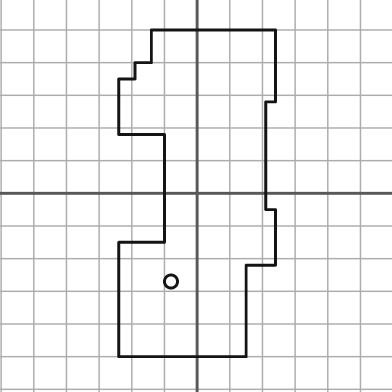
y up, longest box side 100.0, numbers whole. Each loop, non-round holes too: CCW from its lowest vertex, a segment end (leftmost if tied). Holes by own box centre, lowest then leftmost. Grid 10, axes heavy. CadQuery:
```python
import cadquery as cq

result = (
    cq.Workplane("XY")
    .moveTo(-24.0, -50.0)
    .lineTo(15.0, -50.0)
    .lineTo(15.0, -22.0)
    .lineTo(24.0, -22.0)
    .lineTo(24.0, -5.0)
    .lineTo(21.0, -5.0)
    .lineTo(21.0, 28.0)
    .lineTo(24.0, 28.0)
    .lineTo(24.0, 50.0)
    .lineTo(-14.0, 50.0)
    .lineTo(-14.0, 40.0)
    .lineTo(-19.0, 40.0)
    .lineTo(-19.0, 35.0)
    .lineTo(-24.0, 35.0)
    .lineTo(-24.0, 18.0)
    .lineTo(-10.0, 18.0)
    .lineTo(-10.0, -15.0)
    .lineTo(-24.0, -15.0)
    .close()
    .moveTo(-8.0, -27.0)
    .circle(2.0)
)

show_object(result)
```